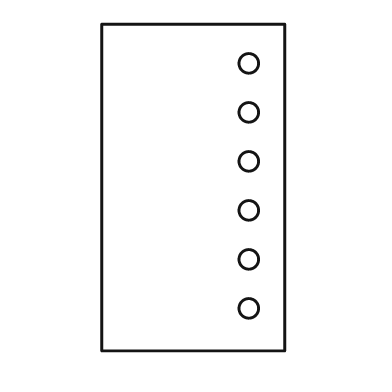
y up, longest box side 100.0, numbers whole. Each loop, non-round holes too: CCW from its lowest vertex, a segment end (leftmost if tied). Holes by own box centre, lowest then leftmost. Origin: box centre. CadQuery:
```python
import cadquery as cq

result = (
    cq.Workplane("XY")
    .moveTo(-28.0, -50.0)
    .lineTo(28.0, -50.0)
    .lineTo(28.0, 50.0)
    .lineTo(-28.0, 50.0)
    .close()
    .moveTo(17.0, -37.0)
    .circle(3.0)
    .moveTo(17.0, -22.0)
    .circle(3.0)
    .moveTo(17.0, -7.0)
    .circle(3.0)
    .moveTo(17.0, 8.0)
    .circle(3.0)
    .moveTo(17.0, 23.0)
    .circle(3.0)
    .moveTo(17.0, 38.0)
    .circle(3.0)
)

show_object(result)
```